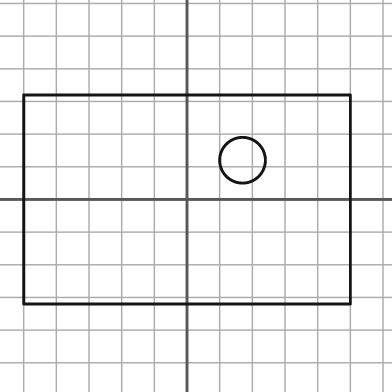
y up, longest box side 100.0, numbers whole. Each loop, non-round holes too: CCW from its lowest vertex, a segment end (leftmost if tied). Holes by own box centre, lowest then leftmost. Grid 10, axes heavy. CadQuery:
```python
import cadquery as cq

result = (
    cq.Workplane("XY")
    .moveTo(-50.0, -32.0)
    .lineTo(50.0, -32.0)
    .lineTo(50.0, 32.0)
    .lineTo(-50.0, 32.0)
    .close()
    .moveTo(17.0, 12.0)
    .circle(7.0)
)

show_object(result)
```